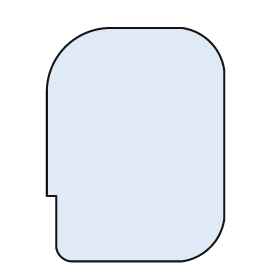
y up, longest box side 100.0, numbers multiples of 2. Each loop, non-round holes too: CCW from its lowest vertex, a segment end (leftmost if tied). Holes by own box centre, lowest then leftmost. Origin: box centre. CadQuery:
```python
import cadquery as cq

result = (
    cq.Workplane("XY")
    .moveTo(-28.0, -50.0)
    .lineTo(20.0, -50.0)
    .threePointArc((32.0, -44.0), (38.0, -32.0))
    .lineTo(38.0, 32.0)
    .threePointArc((32.0, 44.0), (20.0, 50.0))
    .lineTo(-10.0, 50.0)
    .threePointArc((-30.0, 42.0), (-38.0, 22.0))
    .lineTo(-38.0, -22.0)
    .lineTo(-34.0, -22.0)
    .lineTo(-34.0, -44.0)
    .threePointArc((-32.0, -48.0), (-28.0, -50.0))
    .close()
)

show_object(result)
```